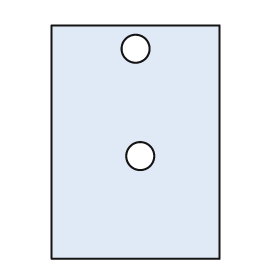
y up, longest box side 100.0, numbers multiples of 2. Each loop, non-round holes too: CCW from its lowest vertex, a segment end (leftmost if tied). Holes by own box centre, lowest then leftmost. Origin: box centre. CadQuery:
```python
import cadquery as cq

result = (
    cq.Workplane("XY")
    .moveTo(-36.0, -50.0)
    .lineTo(36.0, -50.0)
    .lineTo(36.0, 50.0)
    .lineTo(-36.0, 50.0)
    .close()
    .moveTo(2.0, -6.0)
    .circle(6.0)
    .moveTo(0.0, 40.0)
    .circle(6.0)
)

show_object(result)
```